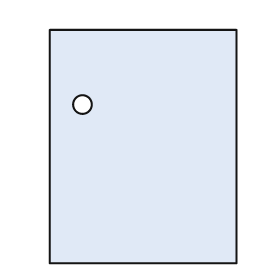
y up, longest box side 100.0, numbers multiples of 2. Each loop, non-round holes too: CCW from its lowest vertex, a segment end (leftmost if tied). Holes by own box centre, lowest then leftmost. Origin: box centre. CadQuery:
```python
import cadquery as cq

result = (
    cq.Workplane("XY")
    .moveTo(-40.0, -50.0)
    .lineTo(40.0, -50.0)
    .lineTo(40.0, 50.0)
    .lineTo(-40.0, 50.0)
    .close()
    .moveTo(-26.0, 18.0)
    .circle(4.0)
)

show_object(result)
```